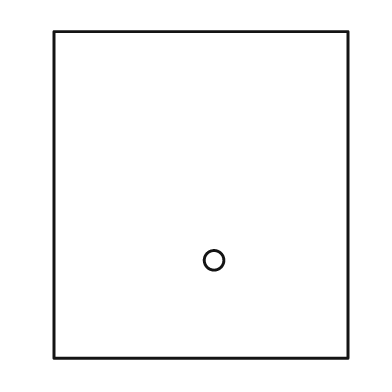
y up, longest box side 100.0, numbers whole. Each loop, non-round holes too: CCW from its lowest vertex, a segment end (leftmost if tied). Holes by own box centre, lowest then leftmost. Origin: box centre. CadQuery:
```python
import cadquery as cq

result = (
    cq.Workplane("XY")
    .moveTo(-45.0, -50.0)
    .lineTo(45.0, -50.0)
    .lineTo(45.0, 50.0)
    .lineTo(-45.0, 50.0)
    .close()
    .moveTo(4.0, -20.0)
    .circle(3.0)
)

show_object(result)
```